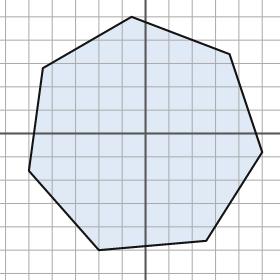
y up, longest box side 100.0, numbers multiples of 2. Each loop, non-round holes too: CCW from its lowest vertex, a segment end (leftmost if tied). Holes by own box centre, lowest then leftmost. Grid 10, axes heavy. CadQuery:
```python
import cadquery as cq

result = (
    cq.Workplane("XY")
    .moveTo(-20.0, -50.0)
    .lineTo(26.0, -46.0)
    .lineTo(50.0, -8.0)
    .lineTo(36.0, 34.0)
    .lineTo(-6.0, 50.0)
    .lineTo(-44.0, 28.0)
    .lineTo(-50.0, -16.0)
    .close()
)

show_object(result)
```